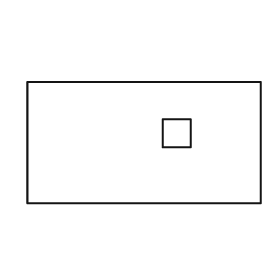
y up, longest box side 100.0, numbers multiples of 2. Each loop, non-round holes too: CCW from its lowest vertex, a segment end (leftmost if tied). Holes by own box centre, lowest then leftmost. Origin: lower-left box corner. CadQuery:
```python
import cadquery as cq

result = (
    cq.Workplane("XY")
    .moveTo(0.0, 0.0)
    .lineTo(100.0, 0.0)
    .lineTo(100.0, 52.0)
    .lineTo(0.0, 52.0)
    .close()
    .moveTo(58.0, 24.0)
    .lineTo(70.0, 24.0)
    .lineTo(70.0, 36.0)
    .lineTo(58.0, 36.0)
    .close()
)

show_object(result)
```